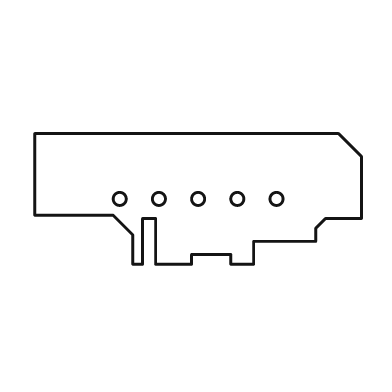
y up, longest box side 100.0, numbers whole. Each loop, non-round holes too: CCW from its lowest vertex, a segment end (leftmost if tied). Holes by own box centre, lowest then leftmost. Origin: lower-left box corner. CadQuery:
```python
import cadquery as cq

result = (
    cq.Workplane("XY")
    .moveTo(30.0, 0.0)
    .lineTo(33.0, 0.0)
    .lineTo(33.0, 14.0)
    .lineTo(37.0, 14.0)
    .lineTo(37.0, 0.0)
    .lineTo(48.0, 0.0)
    .lineTo(48.0, 3.0)
    .lineTo(60.0, 3.0)
    .lineTo(60.0, 0.0)
    .lineTo(67.0, 0.0)
    .lineTo(67.0, 7.0)
    .lineTo(86.0, 7.0)
    .lineTo(86.0, 11.0)
    .lineTo(89.0, 14.0)
    .lineTo(100.0, 14.0)
    .lineTo(100.0, 33.0)
    .lineTo(93.0, 40.0)
    .lineTo(0.0, 40.0)
    .lineTo(0.0, 15.0)
    .lineTo(24.0, 15.0)
    .lineTo(30.0, 9.0)
    .close()
    .moveTo(26.0, 20.0)
    .circle(2.0)
    .moveTo(38.0, 20.0)
    .circle(2.0)
    .moveTo(50.0, 20.0)
    .circle(2.0)
    .moveTo(62.0, 20.0)
    .circle(2.0)
    .moveTo(74.0, 20.0)
    .circle(2.0)
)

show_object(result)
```